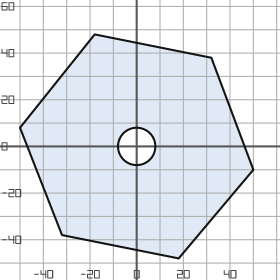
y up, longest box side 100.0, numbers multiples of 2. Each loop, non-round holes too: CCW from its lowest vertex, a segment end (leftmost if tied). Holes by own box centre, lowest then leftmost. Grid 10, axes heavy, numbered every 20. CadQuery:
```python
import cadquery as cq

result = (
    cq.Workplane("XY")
    .moveTo(18.0, -48.0)
    .lineTo(50.0, -10.0)
    .lineTo(32.0, 38.0)
    .lineTo(-18.0, 48.0)
    .lineTo(-50.0, 8.0)
    .lineTo(-32.0, -38.0)
    .close()
    .moveTo(0.0, 0.0)
    .circle(8.0)
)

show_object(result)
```